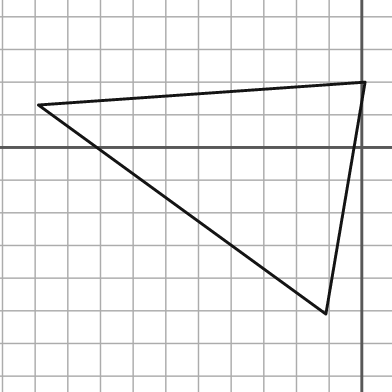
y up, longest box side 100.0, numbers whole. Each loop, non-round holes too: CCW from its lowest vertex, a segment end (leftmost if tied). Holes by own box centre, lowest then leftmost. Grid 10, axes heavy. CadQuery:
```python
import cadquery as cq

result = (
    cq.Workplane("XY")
    .moveTo(-11.0, -51.0)
    .lineTo(1.0, 20.0)
    .lineTo(-99.0, 13.0)
    .close()
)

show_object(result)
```